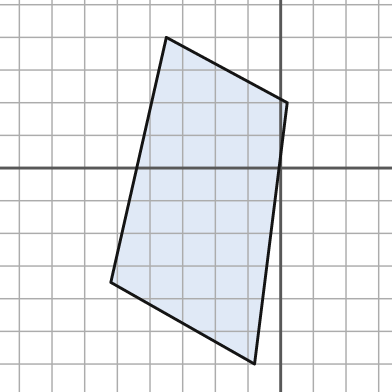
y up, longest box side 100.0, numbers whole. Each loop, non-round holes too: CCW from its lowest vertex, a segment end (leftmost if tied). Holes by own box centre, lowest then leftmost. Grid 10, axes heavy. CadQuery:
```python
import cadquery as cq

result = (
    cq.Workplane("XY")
    .moveTo(-8.0, -60.0)
    .lineTo(2.0, 20.0)
    .lineTo(-35.0, 40.0)
    .lineTo(-52.0, -35.0)
    .close()
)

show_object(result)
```